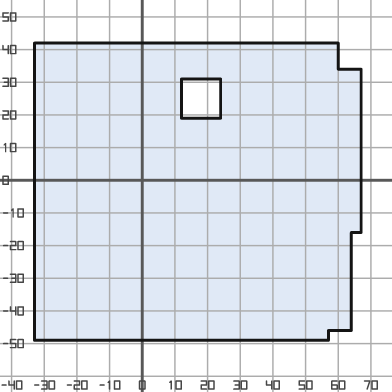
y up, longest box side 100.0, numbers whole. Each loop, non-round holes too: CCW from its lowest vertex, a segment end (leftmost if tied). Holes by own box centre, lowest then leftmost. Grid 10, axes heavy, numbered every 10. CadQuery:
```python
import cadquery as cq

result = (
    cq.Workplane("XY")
    .moveTo(-33.0, -49.0)
    .lineTo(57.0, -49.0)
    .lineTo(57.0, -46.0)
    .lineTo(64.0, -46.0)
    .lineTo(64.0, -16.0)
    .lineTo(67.0, -16.0)
    .lineTo(67.0, 34.0)
    .lineTo(60.0, 34.0)
    .lineTo(60.0, 42.0)
    .lineTo(-33.0, 42.0)
    .close()
    .moveTo(12.0, 19.0)
    .lineTo(24.0, 19.0)
    .lineTo(24.0, 31.0)
    .lineTo(12.0, 31.0)
    .close()
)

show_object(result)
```